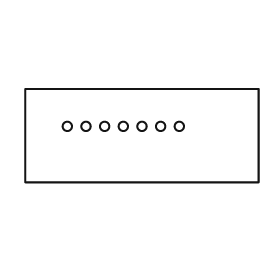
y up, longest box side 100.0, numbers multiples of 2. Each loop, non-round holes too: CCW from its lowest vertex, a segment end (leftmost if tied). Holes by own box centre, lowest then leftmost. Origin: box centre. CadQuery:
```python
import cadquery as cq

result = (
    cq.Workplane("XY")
    .moveTo(-50.0, -20.0)
    .lineTo(50.0, -20.0)
    .lineTo(50.0, 20.0)
    .lineTo(-50.0, 20.0)
    .close()
    .moveTo(-32.0, 4.0)
    .circle(2.0)
    .moveTo(-24.0, 4.0)
    .circle(2.0)
    .moveTo(-16.0, 4.0)
    .circle(2.0)
    .moveTo(-8.0, 4.0)
    .circle(2.0)
    .moveTo(0.0, 4.0)
    .circle(2.0)
    .moveTo(8.0, 4.0)
    .circle(2.0)
    .moveTo(16.0, 4.0)
    .circle(2.0)
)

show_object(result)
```